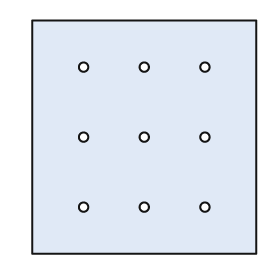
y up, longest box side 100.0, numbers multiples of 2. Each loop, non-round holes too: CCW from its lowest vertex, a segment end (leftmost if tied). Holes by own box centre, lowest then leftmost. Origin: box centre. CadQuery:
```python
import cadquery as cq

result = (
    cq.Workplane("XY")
    .moveTo(-48.0, -50.0)
    .lineTo(48.0, -50.0)
    .lineTo(48.0, 50.0)
    .lineTo(-48.0, 50.0)
    .close()
    .moveTo(-26.0, -30.0)
    .circle(2.0)
    .moveTo(0.0, -30.0)
    .circle(2.0)
    .moveTo(26.0, -30.0)
    .circle(2.0)
    .moveTo(-26.0, 0.0)
    .circle(2.0)
    .moveTo(0.0, 0.0)
    .circle(2.0)
    .moveTo(26.0, 0.0)
    .circle(2.0)
    .moveTo(-26.0, 30.0)
    .circle(2.0)
    .moveTo(0.0, 30.0)
    .circle(2.0)
    .moveTo(26.0, 30.0)
    .circle(2.0)
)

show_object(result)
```